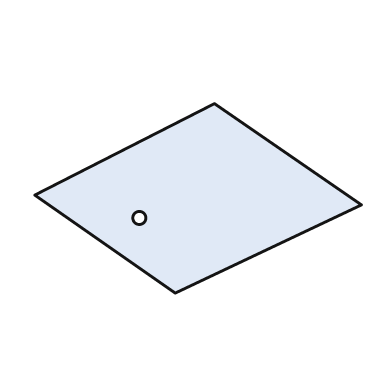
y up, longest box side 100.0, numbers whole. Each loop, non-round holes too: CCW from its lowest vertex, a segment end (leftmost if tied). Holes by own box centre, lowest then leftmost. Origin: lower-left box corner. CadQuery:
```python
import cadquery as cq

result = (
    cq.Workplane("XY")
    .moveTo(43.0, 0.0)
    .lineTo(100.0, 27.0)
    .lineTo(55.0, 58.0)
    .lineTo(0.0, 30.0)
    .close()
    .moveTo(32.0, 23.0)
    .circle(2.0)
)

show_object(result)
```